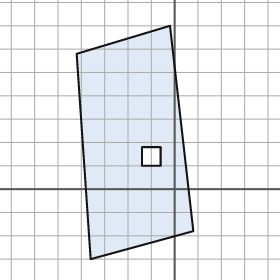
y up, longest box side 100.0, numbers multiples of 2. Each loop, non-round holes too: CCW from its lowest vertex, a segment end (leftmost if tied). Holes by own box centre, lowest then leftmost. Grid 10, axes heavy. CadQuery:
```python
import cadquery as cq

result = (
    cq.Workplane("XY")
    .moveTo(-36.0, -30.0)
    .lineTo(8.0, -18.0)
    .lineTo(-2.0, 70.0)
    .lineTo(-42.0, 58.0)
    .close()
    .moveTo(-14.0, 10.0)
    .lineTo(-6.0, 10.0)
    .lineTo(-6.0, 18.0)
    .lineTo(-14.0, 18.0)
    .close()
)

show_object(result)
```